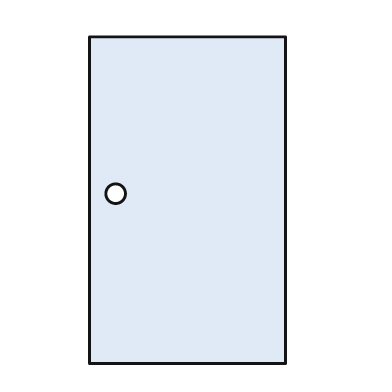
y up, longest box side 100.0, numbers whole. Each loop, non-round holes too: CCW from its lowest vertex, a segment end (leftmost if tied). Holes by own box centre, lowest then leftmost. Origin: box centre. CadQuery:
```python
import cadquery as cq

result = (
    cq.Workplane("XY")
    .moveTo(-30.0, -50.0)
    .lineTo(30.0, -50.0)
    .lineTo(30.0, 50.0)
    .lineTo(-30.0, 50.0)
    .close()
    .moveTo(-22.0, 2.0)
    .circle(3.0)
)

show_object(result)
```